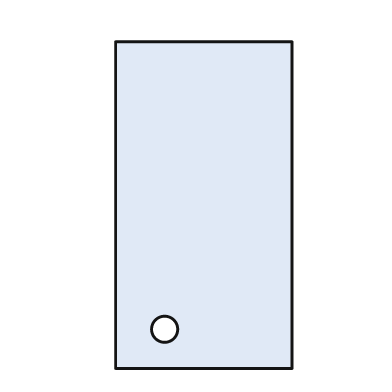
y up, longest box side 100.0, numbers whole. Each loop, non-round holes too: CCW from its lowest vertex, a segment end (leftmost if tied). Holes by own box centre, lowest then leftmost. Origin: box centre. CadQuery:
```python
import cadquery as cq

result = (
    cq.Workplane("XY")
    .moveTo(-27.0, -50.0)
    .lineTo(27.0, -50.0)
    .lineTo(27.0, 50.0)
    .lineTo(-27.0, 50.0)
    .close()
    .moveTo(-12.0, -38.0)
    .circle(4.0)
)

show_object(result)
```